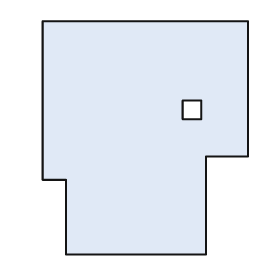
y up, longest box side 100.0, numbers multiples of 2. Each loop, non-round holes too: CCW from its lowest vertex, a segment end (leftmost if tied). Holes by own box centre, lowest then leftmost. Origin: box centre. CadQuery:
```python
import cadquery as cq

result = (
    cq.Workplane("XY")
    .moveTo(-34.0, -50.0)
    .lineTo(26.0, -50.0)
    .lineTo(26.0, -8.0)
    .lineTo(44.0, -8.0)
    .lineTo(44.0, 50.0)
    .lineTo(-44.0, 50.0)
    .lineTo(-44.0, -18.0)
    .lineTo(-34.0, -18.0)
    .close()
    .moveTo(16.0, 8.0)
    .lineTo(24.0, 8.0)
    .lineTo(24.0, 16.0)
    .lineTo(16.0, 16.0)
    .close()
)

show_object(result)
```